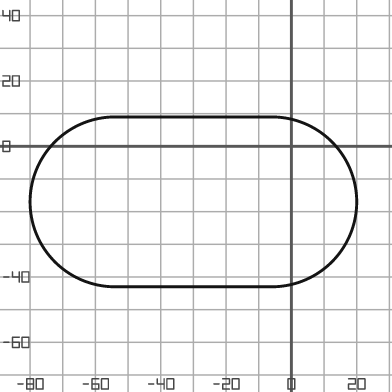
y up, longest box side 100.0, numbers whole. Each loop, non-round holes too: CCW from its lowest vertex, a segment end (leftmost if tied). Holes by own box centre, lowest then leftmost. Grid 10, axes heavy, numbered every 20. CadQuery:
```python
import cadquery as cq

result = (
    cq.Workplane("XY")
    .moveTo(-54.0, -43.0)
    .lineTo(-6.0, -43.0)
    .threePointArc((20.0, -17.0), (-6.0, 9.0))
    .lineTo(-54.0, 9.0)
    .threePointArc((-80.0, -17.0), (-54.0, -43.0))
    .close()
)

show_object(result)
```